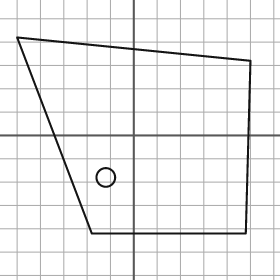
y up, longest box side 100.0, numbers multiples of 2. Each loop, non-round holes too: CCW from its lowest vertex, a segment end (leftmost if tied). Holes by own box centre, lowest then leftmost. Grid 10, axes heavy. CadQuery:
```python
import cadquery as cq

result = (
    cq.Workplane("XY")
    .moveTo(-18.0, -42.0)
    .lineTo(48.0, -42.0)
    .lineTo(50.0, 32.0)
    .lineTo(-50.0, 42.0)
    .close()
    .moveTo(-12.0, -18.0)
    .circle(4.0)
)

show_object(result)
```